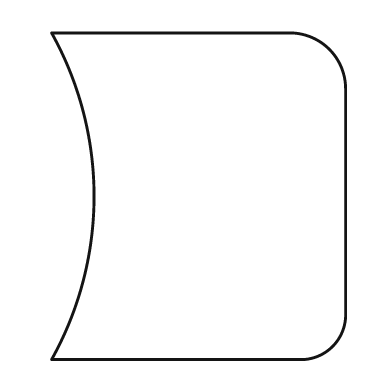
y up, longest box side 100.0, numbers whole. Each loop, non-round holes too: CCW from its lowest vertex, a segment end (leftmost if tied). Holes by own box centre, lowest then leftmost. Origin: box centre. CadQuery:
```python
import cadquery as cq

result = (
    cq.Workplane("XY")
    .moveTo(-45.0, -50.0)
    .lineTo(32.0, -50.0)
    .threePointArc((41.0, -46.0), (45.0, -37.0))
    .lineTo(45.0, 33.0)
    .threePointArc((40.0, 45.0), (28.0, 50.0))
    .lineTo(-45.0, 50.0)
    .threePointArc((-32.0, 0.0), (-45.0, -50.0))
    .close()
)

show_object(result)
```